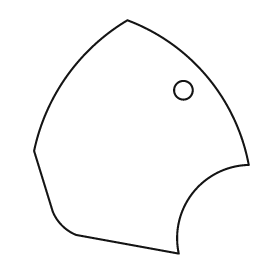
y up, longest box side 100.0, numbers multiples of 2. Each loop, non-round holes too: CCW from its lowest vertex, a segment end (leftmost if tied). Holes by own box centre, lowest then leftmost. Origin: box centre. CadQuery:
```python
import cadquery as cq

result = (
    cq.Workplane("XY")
    .moveTo(16.0, -50.0)
    .threePointArc((22.0, -24.0), (46.0, -12.0))
    .threePointArc((28.0, 26.0), (-6.0, 50.0))
    .threePointArc((-32.0, 26.0), (-46.0, -6.0))
    .lineTo(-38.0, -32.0)
    .threePointArc((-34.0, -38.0), (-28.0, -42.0))
    .close()
    .moveTo(18.0, 20.0)
    .circle(4.0)
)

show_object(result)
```